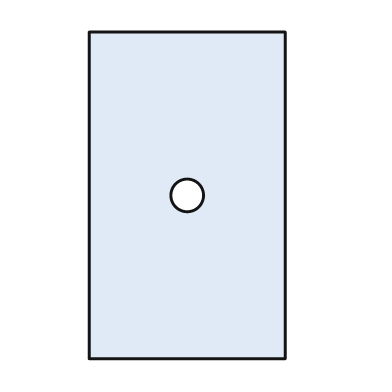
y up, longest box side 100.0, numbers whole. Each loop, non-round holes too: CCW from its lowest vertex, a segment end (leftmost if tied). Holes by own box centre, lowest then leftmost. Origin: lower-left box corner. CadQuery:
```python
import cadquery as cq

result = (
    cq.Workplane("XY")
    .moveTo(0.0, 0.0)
    .lineTo(60.0, 0.0)
    .lineTo(60.0, 100.0)
    .lineTo(0.0, 100.0)
    .close()
    .moveTo(30.0, 50.0)
    .circle(5.0)
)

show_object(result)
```